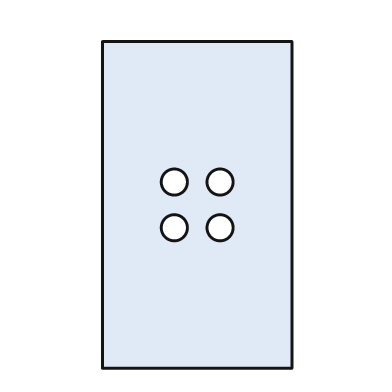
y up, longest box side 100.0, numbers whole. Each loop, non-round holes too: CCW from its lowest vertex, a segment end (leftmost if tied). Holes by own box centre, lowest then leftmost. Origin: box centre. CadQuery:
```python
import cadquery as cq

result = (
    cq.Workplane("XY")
    .moveTo(-29.0, -50.0)
    .lineTo(29.0, -50.0)
    .lineTo(29.0, 50.0)
    .lineTo(-29.0, 50.0)
    .close()
    .moveTo(-7.0, -7.0)
    .circle(4.0)
    .moveTo(7.0, -7.0)
    .circle(4.0)
    .moveTo(-7.0, 7.0)
    .circle(4.0)
    .moveTo(7.0, 7.0)
    .circle(4.0)
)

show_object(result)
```